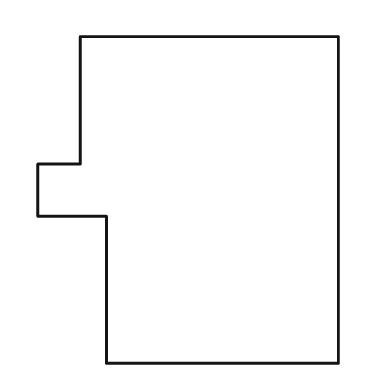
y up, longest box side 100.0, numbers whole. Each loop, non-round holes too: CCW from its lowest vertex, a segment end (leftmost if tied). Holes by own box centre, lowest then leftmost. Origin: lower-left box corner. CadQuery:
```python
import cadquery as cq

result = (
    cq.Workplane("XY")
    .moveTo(21.0, 0.0)
    .lineTo(92.0, 0.0)
    .lineTo(92.0, 100.0)
    .lineTo(13.0, 100.0)
    .lineTo(13.0, 61.0)
    .lineTo(0.0, 61.0)
    .lineTo(0.0, 45.0)
    .lineTo(21.0, 45.0)
    .close()
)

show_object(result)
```